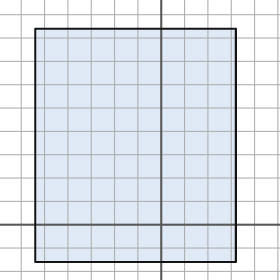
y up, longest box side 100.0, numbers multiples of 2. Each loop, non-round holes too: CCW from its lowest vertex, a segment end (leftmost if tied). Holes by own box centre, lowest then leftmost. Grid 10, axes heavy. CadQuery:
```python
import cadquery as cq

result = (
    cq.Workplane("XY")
    .moveTo(-54.0, -16.0)
    .lineTo(32.0, -16.0)
    .lineTo(32.0, 84.0)
    .lineTo(-54.0, 84.0)
    .close()
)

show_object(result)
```